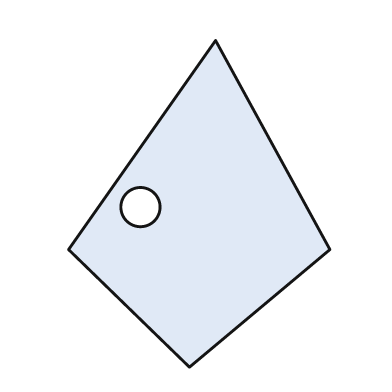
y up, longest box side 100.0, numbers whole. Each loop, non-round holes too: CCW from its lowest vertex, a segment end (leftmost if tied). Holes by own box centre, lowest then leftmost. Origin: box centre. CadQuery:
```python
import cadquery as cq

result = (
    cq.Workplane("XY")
    .moveTo(-3.0, -50.0)
    .lineTo(40.0, -14.0)
    .lineTo(5.0, 50.0)
    .lineTo(-40.0, -14.0)
    .close()
    .moveTo(-18.0, -1.0)
    .circle(6.0)
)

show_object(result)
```